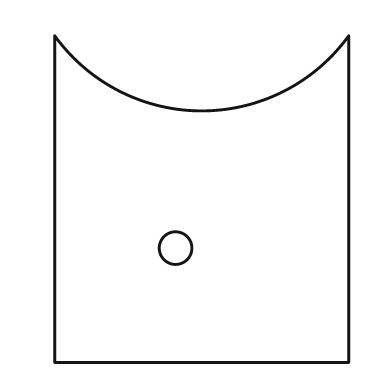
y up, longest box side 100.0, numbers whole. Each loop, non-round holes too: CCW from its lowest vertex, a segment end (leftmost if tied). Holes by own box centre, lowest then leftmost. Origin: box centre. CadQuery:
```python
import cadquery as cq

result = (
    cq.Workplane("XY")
    .moveTo(-45.0, -50.0)
    .lineTo(45.0, -50.0)
    .lineTo(45.0, 50.0)
    .threePointArc((0.0, 27.0), (-45.0, 50.0))
    .close()
    .moveTo(-8.0, -15.0)
    .circle(5.0)
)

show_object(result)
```